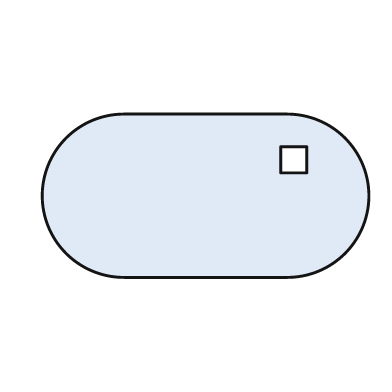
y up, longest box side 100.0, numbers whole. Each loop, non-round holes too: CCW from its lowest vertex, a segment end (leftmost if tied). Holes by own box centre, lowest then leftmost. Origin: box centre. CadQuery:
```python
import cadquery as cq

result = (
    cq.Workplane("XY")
    .moveTo(-25.0, -25.0)
    .lineTo(25.0, -25.0)
    .threePointArc((50.0, 0.0), (25.0, 25.0))
    .lineTo(-25.0, 25.0)
    .threePointArc((-50.0, 0.0), (-25.0, -25.0))
    .close()
    .moveTo(23.0, 7.0)
    .lineTo(31.0, 7.0)
    .lineTo(31.0, 15.0)
    .lineTo(23.0, 15.0)
    .close()
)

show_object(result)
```